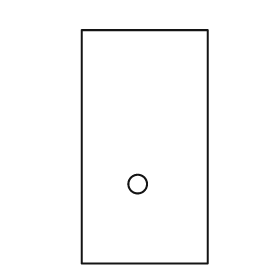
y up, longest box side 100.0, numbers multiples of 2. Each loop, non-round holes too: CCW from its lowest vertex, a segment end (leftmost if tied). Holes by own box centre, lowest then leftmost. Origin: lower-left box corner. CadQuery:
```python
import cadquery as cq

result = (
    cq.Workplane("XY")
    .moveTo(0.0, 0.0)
    .lineTo(54.0, 0.0)
    .lineTo(54.0, 100.0)
    .lineTo(0.0, 100.0)
    .close()
    .moveTo(24.0, 34.0)
    .circle(4.0)
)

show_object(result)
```